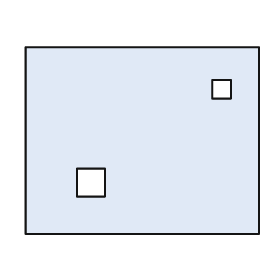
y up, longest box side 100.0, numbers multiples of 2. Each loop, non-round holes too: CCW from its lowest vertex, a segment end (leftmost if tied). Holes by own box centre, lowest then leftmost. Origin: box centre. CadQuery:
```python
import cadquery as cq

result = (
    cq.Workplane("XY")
    .moveTo(-50.0, -40.0)
    .lineTo(50.0, -40.0)
    .lineTo(50.0, 40.0)
    .lineTo(-50.0, 40.0)
    .close()
    .moveTo(-28.0, -24.0)
    .lineTo(-16.0, -24.0)
    .lineTo(-16.0, -12.0)
    .lineTo(-28.0, -12.0)
    .close()
    .moveTo(30.0, 18.0)
    .lineTo(38.0, 18.0)
    .lineTo(38.0, 26.0)
    .lineTo(30.0, 26.0)
    .close()
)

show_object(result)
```